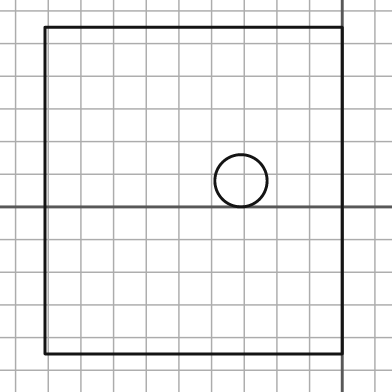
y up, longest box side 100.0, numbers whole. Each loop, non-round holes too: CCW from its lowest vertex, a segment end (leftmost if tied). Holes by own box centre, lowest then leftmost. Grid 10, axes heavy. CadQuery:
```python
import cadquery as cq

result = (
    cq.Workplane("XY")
    .moveTo(-91.0, -45.0)
    .lineTo(0.0, -45.0)
    .lineTo(0.0, 55.0)
    .lineTo(-91.0, 55.0)
    .close()
    .moveTo(-31.0, 8.0)
    .circle(8.0)
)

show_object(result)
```